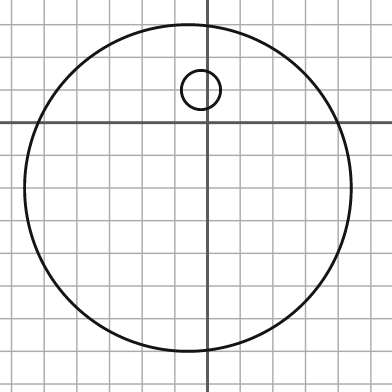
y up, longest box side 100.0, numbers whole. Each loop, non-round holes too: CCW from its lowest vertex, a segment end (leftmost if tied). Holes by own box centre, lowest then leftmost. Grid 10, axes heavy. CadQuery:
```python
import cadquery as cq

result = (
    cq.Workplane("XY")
    .moveTo(-6.0, -20.0)
    .circle(50.0)
    .moveTo(-2.0, 10.0)
    .circle(6.0)
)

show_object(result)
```